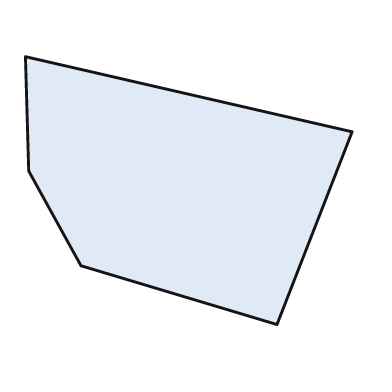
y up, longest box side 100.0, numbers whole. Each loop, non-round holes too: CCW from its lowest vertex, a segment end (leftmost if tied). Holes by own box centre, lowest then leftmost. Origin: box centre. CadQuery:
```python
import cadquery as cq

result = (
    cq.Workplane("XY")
    .moveTo(27.0, -41.0)
    .lineTo(50.0, 18.0)
    .lineTo(-50.0, 41.0)
    .lineTo(-49.0, 6.0)
    .lineTo(-33.0, -23.0)
    .close()
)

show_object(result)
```